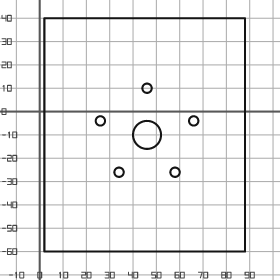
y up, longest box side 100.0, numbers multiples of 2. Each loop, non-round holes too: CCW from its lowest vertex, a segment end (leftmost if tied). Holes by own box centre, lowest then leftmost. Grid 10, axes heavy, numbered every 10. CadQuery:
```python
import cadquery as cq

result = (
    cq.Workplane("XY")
    .moveTo(2.0, -60.0)
    .lineTo(88.0, -60.0)
    .lineTo(88.0, 40.0)
    .lineTo(2.0, 40.0)
    .close()
    .moveTo(34.0, -26.0)
    .circle(2.0)
    .moveTo(58.0, -26.0)
    .circle(2.0)
    .moveTo(46.0, -10.0)
    .circle(6.0)
    .moveTo(26.0, -4.0)
    .circle(2.0)
    .moveTo(66.0, -4.0)
    .circle(2.0)
    .moveTo(46.0, 10.0)
    .circle(2.0)
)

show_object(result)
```